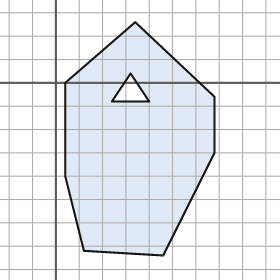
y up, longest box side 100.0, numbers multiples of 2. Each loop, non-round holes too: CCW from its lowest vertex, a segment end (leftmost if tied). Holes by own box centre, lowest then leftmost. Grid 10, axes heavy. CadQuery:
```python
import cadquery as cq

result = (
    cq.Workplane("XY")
    .moveTo(46.0, -74.0)
    .lineTo(68.0, -30.0)
    .lineTo(68.0, -6.0)
    .lineTo(34.0, 26.0)
    .lineTo(4.0, 0.0)
    .lineTo(4.0, -40.0)
    .lineTo(12.0, -72.0)
    .close()
    .moveTo(24.0, -8.0)
    .lineTo(40.0, -8.0)
    .lineTo(32.0, 4.0)
    .close()
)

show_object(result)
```